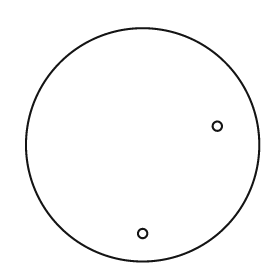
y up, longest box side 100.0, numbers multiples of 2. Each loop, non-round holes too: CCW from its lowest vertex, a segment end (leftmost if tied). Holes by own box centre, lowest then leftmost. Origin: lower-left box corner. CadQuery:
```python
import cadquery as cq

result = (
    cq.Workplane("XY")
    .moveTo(50.0, 50.0)
    .circle(50.0)
    .moveTo(50.0, 12.0)
    .circle(2.0)
    .moveTo(82.0, 58.0)
    .circle(2.0)
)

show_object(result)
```